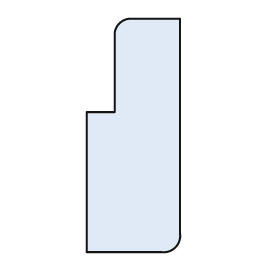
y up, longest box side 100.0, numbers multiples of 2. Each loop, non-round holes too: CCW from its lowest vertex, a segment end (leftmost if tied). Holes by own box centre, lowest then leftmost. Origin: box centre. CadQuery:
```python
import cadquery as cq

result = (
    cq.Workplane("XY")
    .moveTo(-20.0, -50.0)
    .lineTo(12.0, -50.0)
    .threePointArc((18.0, -48.0), (20.0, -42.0))
    .lineTo(20.0, 50.0)
    .lineTo(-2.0, 50.0)
    .threePointArc((-6.0, 48.0), (-8.0, 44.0))
    .lineTo(-8.0, 10.0)
    .lineTo(-20.0, 10.0)
    .close()
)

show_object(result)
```